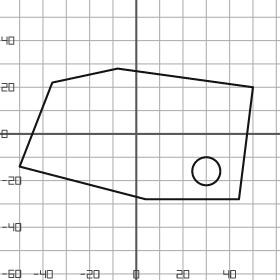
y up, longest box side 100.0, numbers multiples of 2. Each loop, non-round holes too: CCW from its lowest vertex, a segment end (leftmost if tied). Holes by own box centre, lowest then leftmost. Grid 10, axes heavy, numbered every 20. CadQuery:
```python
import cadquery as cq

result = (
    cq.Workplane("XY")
    .moveTo(4.0, -28.0)
    .lineTo(44.0, -28.0)
    .lineTo(50.0, 20.0)
    .lineTo(-8.0, 28.0)
    .lineTo(-36.0, 22.0)
    .lineTo(-50.0, -14.0)
    .close()
    .moveTo(30.0, -16.0)
    .circle(6.0)
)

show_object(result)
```